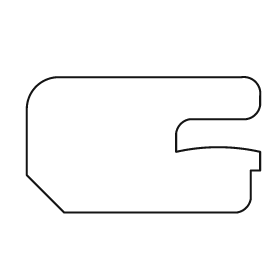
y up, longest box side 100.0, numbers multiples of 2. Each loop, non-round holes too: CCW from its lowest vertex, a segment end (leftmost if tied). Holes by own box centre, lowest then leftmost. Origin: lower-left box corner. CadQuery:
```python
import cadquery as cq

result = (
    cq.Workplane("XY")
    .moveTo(16.0, 0.0)
    .lineTo(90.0, 0.0)
    .threePointArc((94.0, 2.0), (96.0, 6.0))
    .lineTo(96.0, 18.0)
    .lineTo(100.0, 18.0)
    .lineTo(100.0, 26.0)
    .threePointArc((82.0, 28.0), (64.0, 26.0))
    .lineTo(64.0, 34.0)
    .threePointArc((66.0, 38.0), (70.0, 40.0))
    .lineTo(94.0, 40.0)
    .threePointArc((98.0, 42.0), (100.0, 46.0))
    .lineTo(100.0, 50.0)
    .threePointArc((98.0, 56.0), (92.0, 58.0))
    .lineTo(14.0, 58.0)
    .threePointArc((4.0, 54.0), (0.0, 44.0))
    .lineTo(0.0, 16.0)
    .close()
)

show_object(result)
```